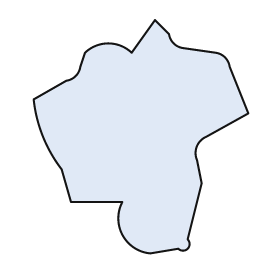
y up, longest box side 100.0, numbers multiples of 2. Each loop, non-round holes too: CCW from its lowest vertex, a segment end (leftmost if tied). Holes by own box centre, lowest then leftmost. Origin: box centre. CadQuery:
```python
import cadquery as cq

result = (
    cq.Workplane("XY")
    .moveTo(4.0, -50.0)
    .lineTo(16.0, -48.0)
    .threePointArc((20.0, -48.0), (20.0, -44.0))
    .lineTo(26.0, -20.0)
    .lineTo(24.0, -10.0)
    .threePointArc((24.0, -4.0), (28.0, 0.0))
    .lineTo(46.0, 10.0)
    .lineTo(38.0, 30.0)
    .threePointArc((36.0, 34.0), (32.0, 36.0))
    .lineTo(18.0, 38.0)
    .threePointArc((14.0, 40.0), (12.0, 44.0))
    .lineTo(6.0, 50.0)
    .lineTo(-4.0, 36.0)
    .threePointArc((-14.0, 40.0), (-24.0, 36.0))
    .lineTo(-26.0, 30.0)
    .threePointArc((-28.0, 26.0), (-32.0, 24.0))
    .lineTo(-46.0, 16.0)
    .threePointArc((-42.0, 0.0), (-34.0, -14.0))
    .lineTo(-30.0, -28.0)
    .lineTo(-8.0, -28.0)
    .threePointArc((-8.0, -42.0), (4.0, -50.0))
    .close()
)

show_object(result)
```